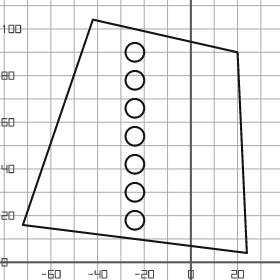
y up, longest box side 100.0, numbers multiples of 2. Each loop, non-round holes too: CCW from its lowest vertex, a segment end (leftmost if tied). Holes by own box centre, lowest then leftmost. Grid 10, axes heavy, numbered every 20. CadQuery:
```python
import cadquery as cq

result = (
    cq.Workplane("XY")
    .moveTo(24.0, 4.0)
    .lineTo(20.0, 90.0)
    .lineTo(-42.0, 104.0)
    .lineTo(-72.0, 16.0)
    .close()
    .moveTo(-24.0, 18.0)
    .circle(4.0)
    .moveTo(-24.0, 30.0)
    .circle(4.0)
    .moveTo(-24.0, 42.0)
    .circle(4.0)
    .moveTo(-24.0, 54.0)
    .circle(4.0)
    .moveTo(-24.0, 66.0)
    .circle(4.0)
    .moveTo(-24.0, 78.0)
    .circle(4.0)
    .moveTo(-24.0, 90.0)
    .circle(4.0)
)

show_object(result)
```